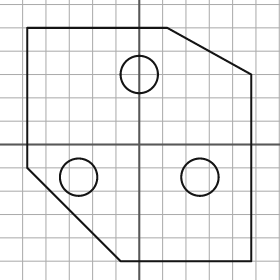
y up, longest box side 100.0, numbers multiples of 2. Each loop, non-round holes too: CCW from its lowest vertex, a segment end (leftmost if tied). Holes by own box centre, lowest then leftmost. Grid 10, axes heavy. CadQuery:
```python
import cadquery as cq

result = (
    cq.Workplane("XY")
    .moveTo(-8.0, -50.0)
    .lineTo(48.0, -50.0)
    .lineTo(48.0, 30.0)
    .lineTo(12.0, 50.0)
    .lineTo(-48.0, 50.0)
    .lineTo(-48.0, -10.0)
    .close()
    .moveTo(-26.0, -14.0)
    .circle(8.0)
    .moveTo(26.0, -14.0)
    .circle(8.0)
    .moveTo(0.0, 30.0)
    .circle(8.0)
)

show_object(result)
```